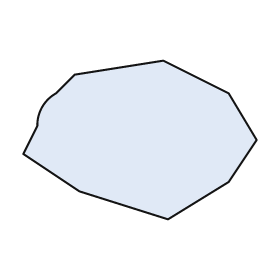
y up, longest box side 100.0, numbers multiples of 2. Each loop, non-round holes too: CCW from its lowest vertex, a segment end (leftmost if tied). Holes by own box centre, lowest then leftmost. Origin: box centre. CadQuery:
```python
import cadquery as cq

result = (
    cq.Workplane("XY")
    .moveTo(12.0, -34.0)
    .lineTo(38.0, -18.0)
    .lineTo(50.0, 0.0)
    .lineTo(38.0, 20.0)
    .lineTo(10.0, 34.0)
    .lineTo(-28.0, 28.0)
    .lineTo(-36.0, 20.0)
    .threePointArc((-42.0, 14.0), (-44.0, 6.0))
    .lineTo(-50.0, -6.0)
    .lineTo(-26.0, -22.0)
    .close()
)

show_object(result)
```